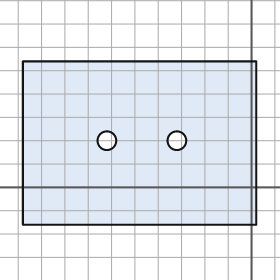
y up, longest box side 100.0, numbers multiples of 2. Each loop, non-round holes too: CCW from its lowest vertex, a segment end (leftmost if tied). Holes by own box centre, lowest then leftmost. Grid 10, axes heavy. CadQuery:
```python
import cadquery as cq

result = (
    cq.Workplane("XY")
    .moveTo(-98.0, -16.0)
    .lineTo(2.0, -16.0)
    .lineTo(2.0, 54.0)
    .lineTo(-98.0, 54.0)
    .close()
    .moveTo(-62.0, 20.0)
    .circle(4.0)
    .moveTo(-32.0, 20.0)
    .circle(4.0)
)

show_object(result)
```